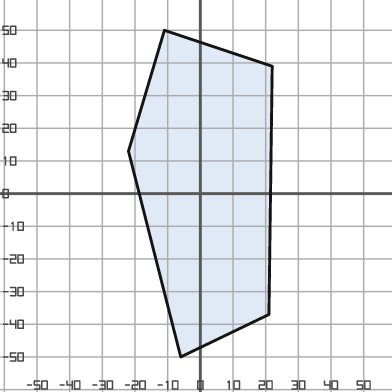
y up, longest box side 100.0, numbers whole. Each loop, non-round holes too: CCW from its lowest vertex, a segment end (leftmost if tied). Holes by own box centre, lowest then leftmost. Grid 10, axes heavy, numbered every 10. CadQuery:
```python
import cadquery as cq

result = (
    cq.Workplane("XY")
    .moveTo(-6.0, -50.0)
    .lineTo(21.0, -37.0)
    .lineTo(22.0, 39.0)
    .lineTo(-11.0, 50.0)
    .lineTo(-22.0, 13.0)
    .close()
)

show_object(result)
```